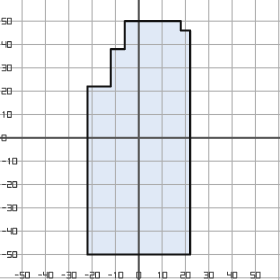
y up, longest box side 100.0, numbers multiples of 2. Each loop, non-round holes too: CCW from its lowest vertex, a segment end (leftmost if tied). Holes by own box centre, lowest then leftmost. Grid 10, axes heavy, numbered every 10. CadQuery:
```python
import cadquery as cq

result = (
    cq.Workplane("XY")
    .moveTo(-22.0, -50.0)
    .lineTo(22.0, -50.0)
    .lineTo(22.0, 46.0)
    .lineTo(18.0, 46.0)
    .lineTo(18.0, 50.0)
    .lineTo(-6.0, 50.0)
    .lineTo(-6.0, 38.0)
    .lineTo(-12.0, 38.0)
    .lineTo(-12.0, 22.0)
    .lineTo(-22.0, 22.0)
    .close()
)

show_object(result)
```